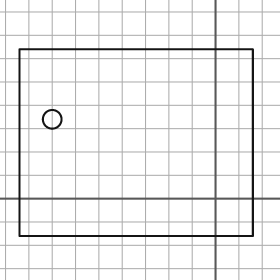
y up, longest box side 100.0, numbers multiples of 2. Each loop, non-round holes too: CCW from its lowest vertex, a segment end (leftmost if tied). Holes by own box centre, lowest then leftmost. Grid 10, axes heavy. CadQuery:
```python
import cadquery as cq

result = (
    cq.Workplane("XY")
    .moveTo(-84.0, -16.0)
    .lineTo(16.0, -16.0)
    .lineTo(16.0, 64.0)
    .lineTo(-84.0, 64.0)
    .close()
    .moveTo(-70.0, 34.0)
    .circle(4.0)
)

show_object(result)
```